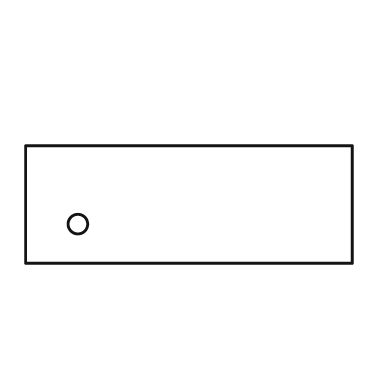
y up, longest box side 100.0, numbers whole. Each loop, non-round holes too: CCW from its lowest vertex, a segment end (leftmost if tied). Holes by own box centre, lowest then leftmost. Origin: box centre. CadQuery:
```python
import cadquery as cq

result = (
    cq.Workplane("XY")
    .moveTo(-50.0, -18.0)
    .lineTo(50.0, -18.0)
    .lineTo(50.0, 18.0)
    .lineTo(-50.0, 18.0)
    .close()
    .moveTo(-34.0, -6.0)
    .circle(3.0)
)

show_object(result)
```